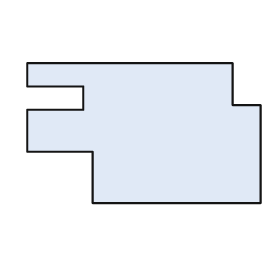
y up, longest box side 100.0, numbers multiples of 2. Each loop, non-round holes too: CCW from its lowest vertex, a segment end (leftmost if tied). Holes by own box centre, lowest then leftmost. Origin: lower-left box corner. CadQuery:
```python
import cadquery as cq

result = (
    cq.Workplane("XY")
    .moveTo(28.0, 0.0)
    .lineTo(100.0, 0.0)
    .lineTo(100.0, 42.0)
    .lineTo(88.0, 42.0)
    .lineTo(88.0, 60.0)
    .lineTo(0.0, 60.0)
    .lineTo(0.0, 50.0)
    .lineTo(24.0, 50.0)
    .lineTo(24.0, 40.0)
    .lineTo(0.0, 40.0)
    .lineTo(0.0, 22.0)
    .lineTo(28.0, 22.0)
    .close()
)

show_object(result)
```